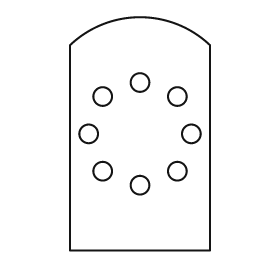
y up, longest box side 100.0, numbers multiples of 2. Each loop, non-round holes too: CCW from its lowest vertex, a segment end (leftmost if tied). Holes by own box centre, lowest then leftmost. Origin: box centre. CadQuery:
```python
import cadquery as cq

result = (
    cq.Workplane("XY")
    .moveTo(-30.0, -50.0)
    .lineTo(30.0, -50.0)
    .lineTo(30.0, 38.0)
    .threePointArc((0.0, 50.0), (-30.0, 38.0))
    .close()
    .moveTo(0.0, -22.0)
    .circle(4.0)
    .moveTo(-16.0, -16.0)
    .circle(4.0)
    .moveTo(16.0, -16.0)
    .circle(4.0)
    .moveTo(-22.0, 0.0)
    .circle(4.0)
    .moveTo(22.0, 0.0)
    .circle(4.0)
    .moveTo(-16.0, 16.0)
    .circle(4.0)
    .moveTo(16.0, 16.0)
    .circle(4.0)
    .moveTo(0.0, 22.0)
    .circle(4.0)
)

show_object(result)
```